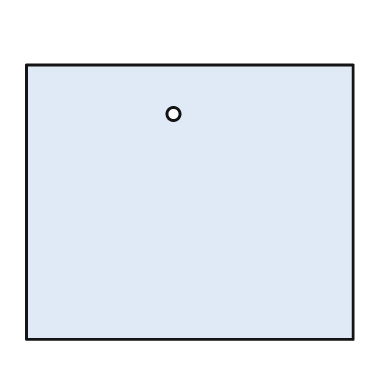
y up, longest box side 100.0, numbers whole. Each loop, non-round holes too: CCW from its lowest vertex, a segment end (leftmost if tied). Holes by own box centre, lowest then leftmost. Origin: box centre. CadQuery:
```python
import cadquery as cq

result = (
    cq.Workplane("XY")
    .moveTo(-50.0, -42.0)
    .lineTo(50.0, -42.0)
    .lineTo(50.0, 42.0)
    .lineTo(-50.0, 42.0)
    .close()
    .moveTo(-5.0, 27.0)
    .circle(2.0)
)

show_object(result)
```